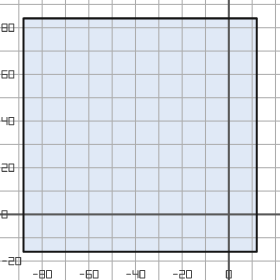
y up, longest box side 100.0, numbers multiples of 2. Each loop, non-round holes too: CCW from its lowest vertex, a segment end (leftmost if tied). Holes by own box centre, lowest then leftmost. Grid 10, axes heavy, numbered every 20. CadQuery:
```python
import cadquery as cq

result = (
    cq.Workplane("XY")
    .moveTo(-88.0, -16.0)
    .lineTo(12.0, -16.0)
    .lineTo(12.0, 84.0)
    .lineTo(-88.0, 84.0)
    .close()
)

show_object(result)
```